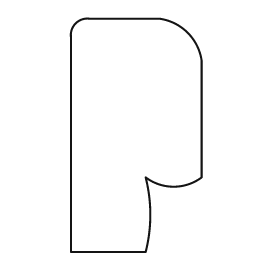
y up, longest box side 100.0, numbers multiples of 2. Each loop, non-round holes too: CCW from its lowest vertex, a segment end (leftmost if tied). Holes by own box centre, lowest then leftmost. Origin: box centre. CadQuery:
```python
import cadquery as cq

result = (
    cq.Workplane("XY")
    .moveTo(-28.0, -50.0)
    .lineTo(4.0, -50.0)
    .threePointArc((6.0, -34.0), (4.0, -18.0))
    .threePointArc((16.0, -22.0), (28.0, -18.0))
    .lineTo(28.0, 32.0)
    .threePointArc((22.0, 44.0), (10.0, 50.0))
    .lineTo(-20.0, 50.0)
    .threePointArc((-26.0, 48.0), (-28.0, 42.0))
    .close()
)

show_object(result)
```